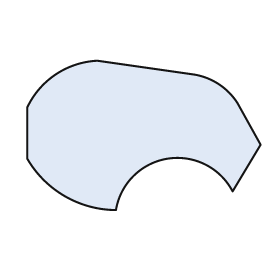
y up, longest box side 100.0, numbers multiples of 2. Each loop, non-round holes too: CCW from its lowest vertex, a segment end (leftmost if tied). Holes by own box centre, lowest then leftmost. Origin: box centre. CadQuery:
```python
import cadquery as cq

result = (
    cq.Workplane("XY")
    .moveTo(-12.0, -32.0)
    .threePointArc((10.0, -10.0), (38.0, -24.0))
    .lineTo(50.0, -4.0)
    .lineTo(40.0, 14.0)
    .threePointArc((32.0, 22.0), (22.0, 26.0))
    .lineTo(-20.0, 32.0)
    .threePointArc((-38.0, 26.0), (-50.0, 12.0))
    .lineTo(-50.0, -10.0)
    .threePointArc((-34.0, -26.0), (-12.0, -32.0))
    .close()
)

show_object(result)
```